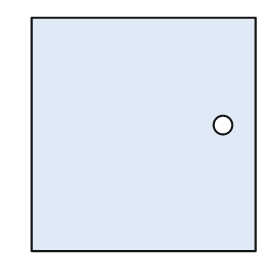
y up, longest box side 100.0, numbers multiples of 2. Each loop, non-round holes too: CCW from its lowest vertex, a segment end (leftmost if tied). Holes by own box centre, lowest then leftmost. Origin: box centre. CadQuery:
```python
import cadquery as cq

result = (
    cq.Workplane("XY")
    .moveTo(-48.0, -50.0)
    .lineTo(48.0, -50.0)
    .lineTo(48.0, 50.0)
    .lineTo(-48.0, 50.0)
    .close()
    .moveTo(34.0, 4.0)
    .circle(4.0)
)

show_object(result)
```